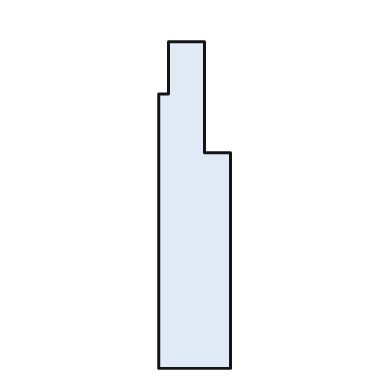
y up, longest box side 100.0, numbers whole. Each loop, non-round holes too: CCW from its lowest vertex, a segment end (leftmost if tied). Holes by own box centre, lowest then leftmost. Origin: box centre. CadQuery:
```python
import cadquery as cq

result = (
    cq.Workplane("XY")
    .moveTo(-11.0, -50.0)
    .lineTo(11.0, -50.0)
    .lineTo(11.0, 16.0)
    .lineTo(3.0, 16.0)
    .lineTo(3.0, 50.0)
    .lineTo(-8.0, 50.0)
    .lineTo(-8.0, 34.0)
    .lineTo(-11.0, 34.0)
    .close()
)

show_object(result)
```